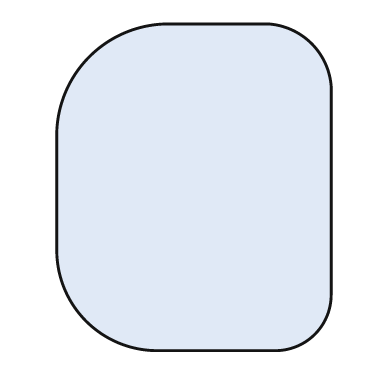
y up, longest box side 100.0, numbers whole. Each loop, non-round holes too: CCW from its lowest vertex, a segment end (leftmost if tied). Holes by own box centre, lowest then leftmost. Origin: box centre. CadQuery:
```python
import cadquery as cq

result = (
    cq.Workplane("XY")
    .moveTo(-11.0, -50.0)
    .lineTo(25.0, -50.0)
    .threePointArc((37.0, -45.0), (42.0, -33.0))
    .lineTo(42.0, 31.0)
    .threePointArc((36.0, 44.0), (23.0, 50.0))
    .lineTo(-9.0, 50.0)
    .threePointArc((-32.0, 40.0), (-42.0, 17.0))
    .lineTo(-42.0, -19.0)
    .threePointArc((-33.0, -41.0), (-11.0, -50.0))
    .close()
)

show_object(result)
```